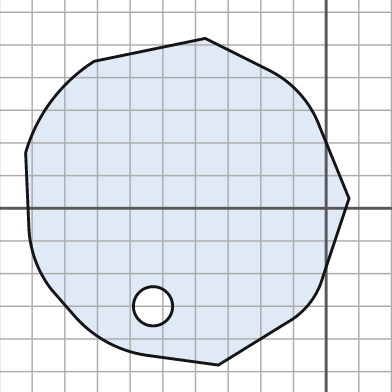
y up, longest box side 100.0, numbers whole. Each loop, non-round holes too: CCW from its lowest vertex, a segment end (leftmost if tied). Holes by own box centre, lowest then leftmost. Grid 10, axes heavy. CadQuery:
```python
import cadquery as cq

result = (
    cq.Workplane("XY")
    .moveTo(-33.0, -48.0)
    .lineTo(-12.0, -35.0)
    .threePointArc((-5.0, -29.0), (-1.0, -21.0))
    .lineTo(7.0, 3.0)
    .lineTo(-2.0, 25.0)
    .threePointArc((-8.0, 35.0), (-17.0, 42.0))
    .lineTo(-37.0, 52.0)
    .lineTo(-71.0, 45.0)
    .threePointArc((-84.0, 33.0), (-92.0, 17.0))
    .lineTo(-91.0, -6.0)
    .threePointArc((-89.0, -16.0), (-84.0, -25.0))
    .lineTo(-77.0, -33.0)
    .threePointArc((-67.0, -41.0), (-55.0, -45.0))
    .close()
    .moveTo(-53.0, -30.0)
    .circle(6.0)
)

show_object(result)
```